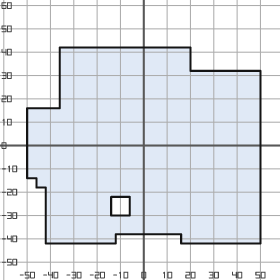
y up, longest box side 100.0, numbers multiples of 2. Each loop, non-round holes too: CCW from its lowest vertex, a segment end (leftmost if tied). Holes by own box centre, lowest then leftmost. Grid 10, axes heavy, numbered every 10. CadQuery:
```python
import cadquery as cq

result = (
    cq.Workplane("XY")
    .moveTo(-42.0, -42.0)
    .lineTo(-12.0, -42.0)
    .lineTo(-12.0, -38.0)
    .lineTo(16.0, -38.0)
    .lineTo(16.0, -42.0)
    .lineTo(50.0, -42.0)
    .lineTo(50.0, 32.0)
    .lineTo(20.0, 32.0)
    .lineTo(20.0, 42.0)
    .lineTo(-36.0, 42.0)
    .lineTo(-36.0, 16.0)
    .lineTo(-50.0, 16.0)
    .lineTo(-50.0, -14.0)
    .lineTo(-46.0, -14.0)
    .lineTo(-46.0, -18.0)
    .lineTo(-42.0, -18.0)
    .close()
    .moveTo(-14.0, -30.0)
    .lineTo(-6.0, -30.0)
    .lineTo(-6.0, -22.0)
    .lineTo(-14.0, -22.0)
    .close()
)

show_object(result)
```